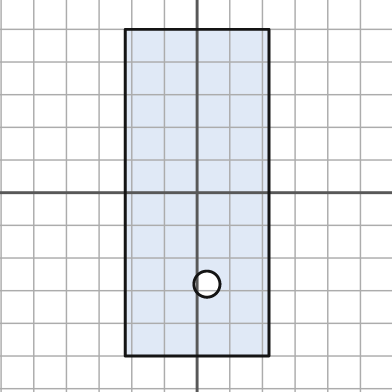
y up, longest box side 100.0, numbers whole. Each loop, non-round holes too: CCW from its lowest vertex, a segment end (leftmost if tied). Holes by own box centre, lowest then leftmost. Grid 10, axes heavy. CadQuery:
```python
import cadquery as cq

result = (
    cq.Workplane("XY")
    .moveTo(-22.0, -50.0)
    .lineTo(22.0, -50.0)
    .lineTo(22.0, 50.0)
    .lineTo(-22.0, 50.0)
    .close()
    .moveTo(3.0, -28.0)
    .circle(4.0)
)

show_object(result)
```